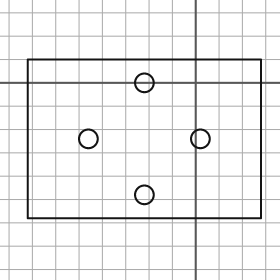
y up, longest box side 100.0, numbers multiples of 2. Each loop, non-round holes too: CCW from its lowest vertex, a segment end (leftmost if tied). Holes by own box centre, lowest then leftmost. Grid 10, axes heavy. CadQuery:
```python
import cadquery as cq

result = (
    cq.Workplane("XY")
    .moveTo(-72.0, -58.0)
    .lineTo(28.0, -58.0)
    .lineTo(28.0, 10.0)
    .lineTo(-72.0, 10.0)
    .close()
    .moveTo(-22.0, -48.0)
    .circle(4.0)
    .moveTo(-46.0, -24.0)
    .circle(4.0)
    .moveTo(2.0, -24.0)
    .circle(4.0)
    .moveTo(-22.0, 0.0)
    .circle(4.0)
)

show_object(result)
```